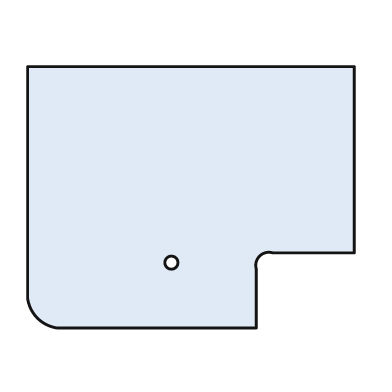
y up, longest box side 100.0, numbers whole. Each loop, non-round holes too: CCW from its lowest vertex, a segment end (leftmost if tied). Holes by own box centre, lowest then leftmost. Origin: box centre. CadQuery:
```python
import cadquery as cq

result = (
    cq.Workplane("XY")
    .moveTo(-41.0, -40.0)
    .lineTo(20.0, -40.0)
    .lineTo(20.0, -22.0)
    .threePointArc((21.0, -18.0), (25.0, -17.0))
    .lineTo(50.0, -17.0)
    .lineTo(50.0, 40.0)
    .lineTo(-50.0, 40.0)
    .lineTo(-50.0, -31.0)
    .threePointArc((-47.0, -37.0), (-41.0, -40.0))
    .close()
    .moveTo(-6.0, -20.0)
    .circle(2.0)
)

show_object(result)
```